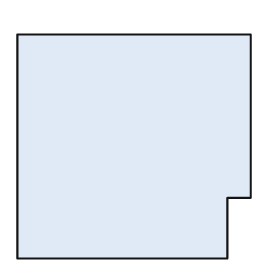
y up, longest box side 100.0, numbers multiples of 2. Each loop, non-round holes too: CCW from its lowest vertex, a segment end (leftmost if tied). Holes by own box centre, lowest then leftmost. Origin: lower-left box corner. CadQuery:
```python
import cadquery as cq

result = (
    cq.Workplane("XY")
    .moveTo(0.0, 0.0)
    .lineTo(90.0, 0.0)
    .lineTo(90.0, 26.0)
    .lineTo(100.0, 26.0)
    .lineTo(100.0, 96.0)
    .lineTo(0.0, 96.0)
    .close()
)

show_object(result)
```